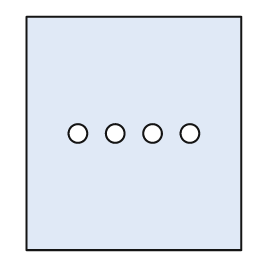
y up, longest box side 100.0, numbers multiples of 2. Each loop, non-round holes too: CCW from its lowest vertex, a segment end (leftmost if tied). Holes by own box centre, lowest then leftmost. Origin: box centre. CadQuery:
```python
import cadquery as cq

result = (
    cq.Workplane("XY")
    .moveTo(-46.0, -50.0)
    .lineTo(46.0, -50.0)
    .lineTo(46.0, 50.0)
    .lineTo(-46.0, 50.0)
    .close()
    .moveTo(-24.0, 0.0)
    .circle(4.0)
    .moveTo(-8.0, 0.0)
    .circle(4.0)
    .moveTo(8.0, 0.0)
    .circle(4.0)
    .moveTo(24.0, 0.0)
    .circle(4.0)
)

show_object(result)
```